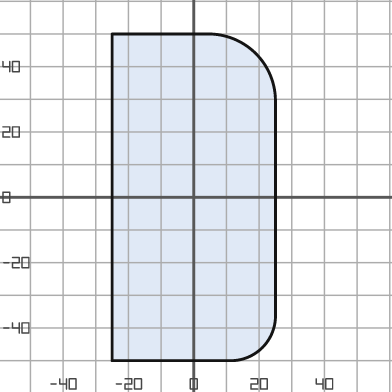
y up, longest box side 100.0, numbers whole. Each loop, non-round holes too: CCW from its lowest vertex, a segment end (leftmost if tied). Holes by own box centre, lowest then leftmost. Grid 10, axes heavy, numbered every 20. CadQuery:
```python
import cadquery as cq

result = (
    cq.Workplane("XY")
    .moveTo(-25.0, -50.0)
    .lineTo(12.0, -50.0)
    .threePointArc((21.0, -46.0), (25.0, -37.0))
    .lineTo(25.0, 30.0)
    .threePointArc((19.0, 44.0), (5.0, 50.0))
    .lineTo(-25.0, 50.0)
    .close()
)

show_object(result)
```